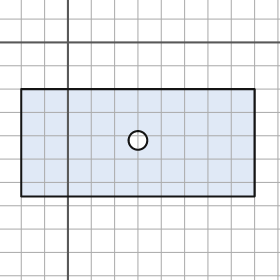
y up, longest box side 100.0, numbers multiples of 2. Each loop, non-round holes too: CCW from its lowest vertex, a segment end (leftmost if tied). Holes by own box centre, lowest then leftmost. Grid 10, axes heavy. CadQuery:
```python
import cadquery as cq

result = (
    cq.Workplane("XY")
    .moveTo(-20.0, -66.0)
    .lineTo(80.0, -66.0)
    .lineTo(80.0, -20.0)
    .lineTo(-20.0, -20.0)
    .close()
    .moveTo(30.0, -42.0)
    .circle(4.0)
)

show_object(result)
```